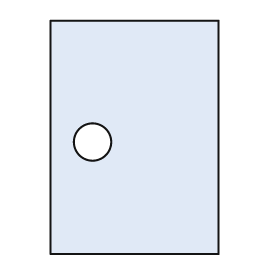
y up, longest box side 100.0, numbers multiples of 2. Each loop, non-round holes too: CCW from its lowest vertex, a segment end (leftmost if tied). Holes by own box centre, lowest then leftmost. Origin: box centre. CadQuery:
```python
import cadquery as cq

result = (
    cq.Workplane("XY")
    .moveTo(-36.0, -50.0)
    .lineTo(36.0, -50.0)
    .lineTo(36.0, 50.0)
    .lineTo(-36.0, 50.0)
    .close()
    .moveTo(-18.0, -2.0)
    .circle(8.0)
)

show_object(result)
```